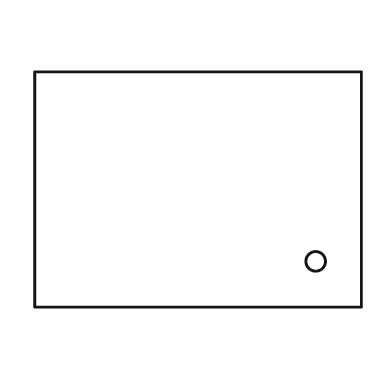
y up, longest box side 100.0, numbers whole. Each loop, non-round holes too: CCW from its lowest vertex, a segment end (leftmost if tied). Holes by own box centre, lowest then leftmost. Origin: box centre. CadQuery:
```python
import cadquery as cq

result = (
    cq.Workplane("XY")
    .moveTo(-50.0, -36.0)
    .lineTo(50.0, -36.0)
    .lineTo(50.0, 36.0)
    .lineTo(-50.0, 36.0)
    .close()
    .moveTo(36.0, -22.0)
    .circle(3.0)
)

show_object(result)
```